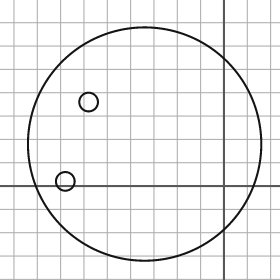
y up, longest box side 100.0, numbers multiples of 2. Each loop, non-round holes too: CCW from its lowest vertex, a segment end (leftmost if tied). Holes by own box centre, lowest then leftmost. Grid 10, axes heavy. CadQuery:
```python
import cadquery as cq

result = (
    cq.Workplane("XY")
    .moveTo(-34.0, 18.0)
    .circle(50.0)
    .moveTo(-68.0, 2.0)
    .circle(4.0)
    .moveTo(-58.0, 36.0)
    .circle(4.0)
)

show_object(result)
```